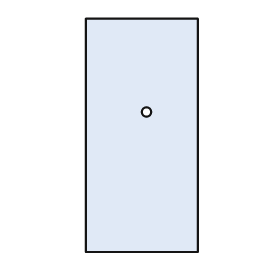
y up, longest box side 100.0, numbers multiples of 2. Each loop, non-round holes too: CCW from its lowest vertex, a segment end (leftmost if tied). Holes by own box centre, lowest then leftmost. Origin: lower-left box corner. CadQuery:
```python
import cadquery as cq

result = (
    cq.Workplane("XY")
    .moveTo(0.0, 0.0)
    .lineTo(48.0, 0.0)
    .lineTo(48.0, 100.0)
    .lineTo(0.0, 100.0)
    .close()
    .moveTo(26.0, 60.0)
    .circle(2.0)
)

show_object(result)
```